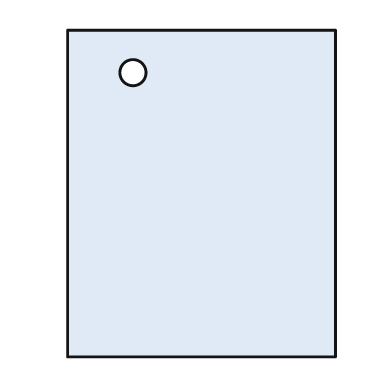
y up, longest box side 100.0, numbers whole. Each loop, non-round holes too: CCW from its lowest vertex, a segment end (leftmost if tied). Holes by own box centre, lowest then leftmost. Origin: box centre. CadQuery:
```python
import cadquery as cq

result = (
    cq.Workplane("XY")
    .moveTo(-41.0, -50.0)
    .lineTo(41.0, -50.0)
    .lineTo(41.0, 50.0)
    .lineTo(-41.0, 50.0)
    .close()
    .moveTo(-21.0, 37.0)
    .circle(4.0)
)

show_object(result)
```